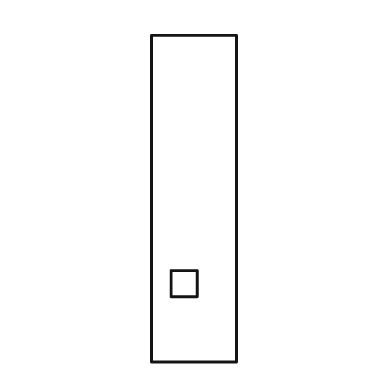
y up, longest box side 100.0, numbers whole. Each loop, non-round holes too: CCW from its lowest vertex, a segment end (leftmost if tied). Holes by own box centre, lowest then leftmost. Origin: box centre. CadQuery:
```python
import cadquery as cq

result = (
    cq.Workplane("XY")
    .moveTo(-13.0, -50.0)
    .lineTo(13.0, -50.0)
    .lineTo(13.0, 50.0)
    .lineTo(-13.0, 50.0)
    .close()
    .moveTo(-7.0, -30.0)
    .lineTo(1.0, -30.0)
    .lineTo(1.0, -22.0)
    .lineTo(-7.0, -22.0)
    .close()
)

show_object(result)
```